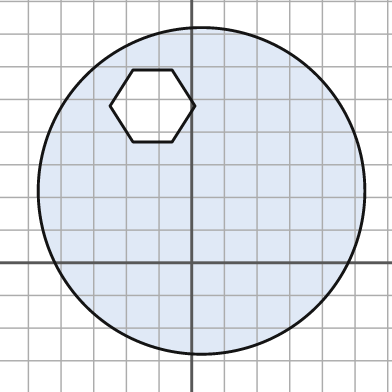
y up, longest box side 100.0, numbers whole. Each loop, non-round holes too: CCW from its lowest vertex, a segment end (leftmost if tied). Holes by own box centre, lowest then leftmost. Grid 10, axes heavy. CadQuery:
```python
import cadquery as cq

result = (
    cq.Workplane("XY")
    .moveTo(3.0, 22.0)
    .circle(50.0)
    .moveTo(-18.0, 37.0)
    .lineTo(-6.0, 37.0)
    .lineTo(1.0, 48.0)
    .lineTo(-6.0, 59.0)
    .lineTo(-18.0, 59.0)
    .lineTo(-25.0, 48.0)
    .close()
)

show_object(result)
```